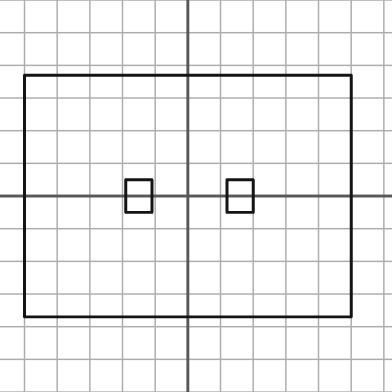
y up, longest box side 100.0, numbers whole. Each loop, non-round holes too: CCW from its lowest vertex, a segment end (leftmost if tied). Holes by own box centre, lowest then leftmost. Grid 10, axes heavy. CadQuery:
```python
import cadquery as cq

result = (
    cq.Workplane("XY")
    .moveTo(-50.0, -37.0)
    .lineTo(50.0, -37.0)
    .lineTo(50.0, 37.0)
    .lineTo(-50.0, 37.0)
    .close()
    .moveTo(-19.0, -5.0)
    .lineTo(-11.0, -5.0)
    .lineTo(-11.0, 5.0)
    .lineTo(-19.0, 5.0)
    .close()
    .moveTo(12.0, -5.0)
    .lineTo(20.0, -5.0)
    .lineTo(20.0, 5.0)
    .lineTo(12.0, 5.0)
    .close()
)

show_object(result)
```